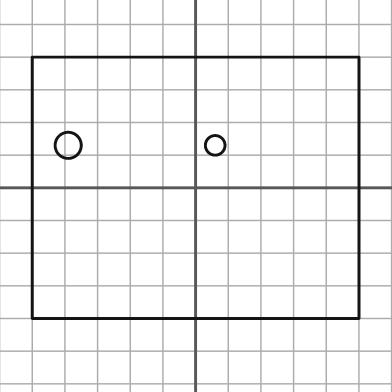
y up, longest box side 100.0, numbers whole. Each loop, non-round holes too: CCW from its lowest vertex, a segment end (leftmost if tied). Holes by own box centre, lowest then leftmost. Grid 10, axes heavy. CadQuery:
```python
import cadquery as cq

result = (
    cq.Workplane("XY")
    .moveTo(-50.0, -40.0)
    .lineTo(50.0, -40.0)
    .lineTo(50.0, 40.0)
    .lineTo(-50.0, 40.0)
    .close()
    .moveTo(-39.0, 13.0)
    .circle(4.0)
    .moveTo(6.0, 13.0)
    .circle(3.0)
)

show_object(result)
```